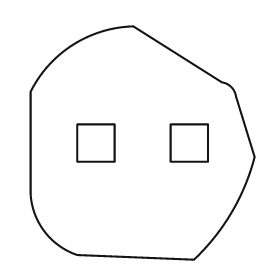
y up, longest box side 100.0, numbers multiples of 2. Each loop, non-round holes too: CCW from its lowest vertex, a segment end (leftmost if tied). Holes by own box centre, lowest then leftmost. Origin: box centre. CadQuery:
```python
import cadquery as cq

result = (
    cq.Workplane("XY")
    .moveTo(22.0, -50.0)
    .threePointArc((38.0, -30.0), (48.0, -6.0))
    .lineTo(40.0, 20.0)
    .threePointArc((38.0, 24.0), (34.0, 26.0))
    .lineTo(-4.0, 50.0)
    .threePointArc((-30.0, 42.0), (-48.0, 22.0))
    .lineTo(-48.0, -22.0)
    .threePointArc((-42.0, -38.0), (-28.0, -48.0))
    .close()
    .moveTo(-28.0, -8.0)
    .lineTo(-12.0, -8.0)
    .lineTo(-12.0, 8.0)
    .lineTo(-28.0, 8.0)
    .close()
    .moveTo(12.0, -8.0)
    .lineTo(28.0, -8.0)
    .lineTo(28.0, 8.0)
    .lineTo(12.0, 8.0)
    .close()
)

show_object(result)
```